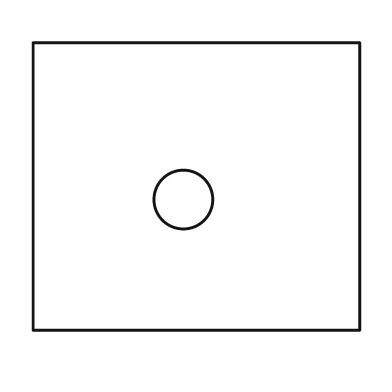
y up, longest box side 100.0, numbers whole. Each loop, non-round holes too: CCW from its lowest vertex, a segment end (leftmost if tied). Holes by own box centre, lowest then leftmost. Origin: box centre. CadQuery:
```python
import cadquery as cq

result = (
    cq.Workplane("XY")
    .moveTo(-50.0, -44.0)
    .lineTo(50.0, -44.0)
    .lineTo(50.0, 44.0)
    .lineTo(-50.0, 44.0)
    .close()
    .moveTo(-4.0, -4.0)
    .circle(9.0)
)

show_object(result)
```